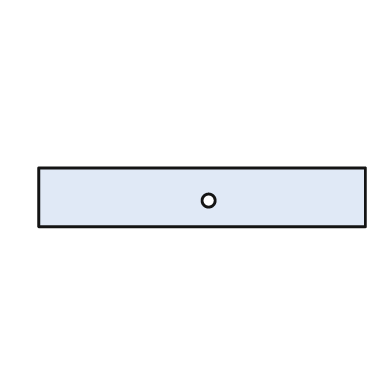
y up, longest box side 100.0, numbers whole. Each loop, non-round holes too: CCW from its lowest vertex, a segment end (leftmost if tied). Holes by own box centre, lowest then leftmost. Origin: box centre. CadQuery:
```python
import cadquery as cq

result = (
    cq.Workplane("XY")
    .moveTo(-50.0, -9.0)
    .lineTo(50.0, -9.0)
    .lineTo(50.0, 9.0)
    .lineTo(-50.0, 9.0)
    .close()
    .moveTo(2.0, -1.0)
    .circle(2.0)
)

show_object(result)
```